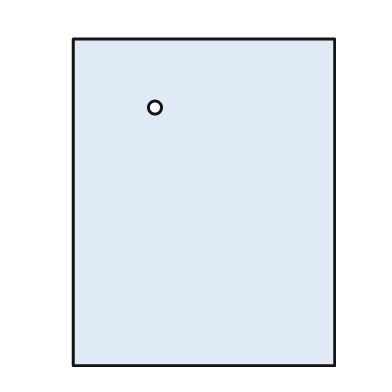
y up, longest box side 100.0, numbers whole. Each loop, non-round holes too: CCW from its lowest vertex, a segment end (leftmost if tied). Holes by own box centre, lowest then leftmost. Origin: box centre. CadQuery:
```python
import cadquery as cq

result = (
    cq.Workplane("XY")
    .moveTo(-40.0, -50.0)
    .lineTo(40.0, -50.0)
    .lineTo(40.0, 50.0)
    .lineTo(-40.0, 50.0)
    .close()
    .moveTo(-15.0, 29.0)
    .circle(2.0)
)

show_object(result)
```